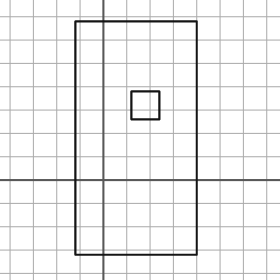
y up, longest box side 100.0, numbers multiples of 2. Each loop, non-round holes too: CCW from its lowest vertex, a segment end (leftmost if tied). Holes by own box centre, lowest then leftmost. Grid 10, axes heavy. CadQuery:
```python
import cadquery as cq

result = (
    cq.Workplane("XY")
    .moveTo(-12.0, -32.0)
    .lineTo(40.0, -32.0)
    .lineTo(40.0, 68.0)
    .lineTo(-12.0, 68.0)
    .close()
    .moveTo(12.0, 26.0)
    .lineTo(24.0, 26.0)
    .lineTo(24.0, 38.0)
    .lineTo(12.0, 38.0)
    .close()
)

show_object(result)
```